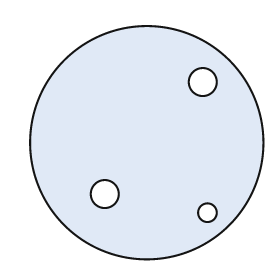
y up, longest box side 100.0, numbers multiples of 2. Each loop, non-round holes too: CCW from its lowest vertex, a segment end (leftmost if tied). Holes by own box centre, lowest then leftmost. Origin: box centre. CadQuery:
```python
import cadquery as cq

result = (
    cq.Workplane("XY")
    .moveTo(0.0, 0.0)
    .circle(50.0)
    .moveTo(26.0, -30.0)
    .circle(4.0)
    .moveTo(-18.0, -22.0)
    .circle(6.0)
    .moveTo(24.0, 26.0)
    .circle(6.0)
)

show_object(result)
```